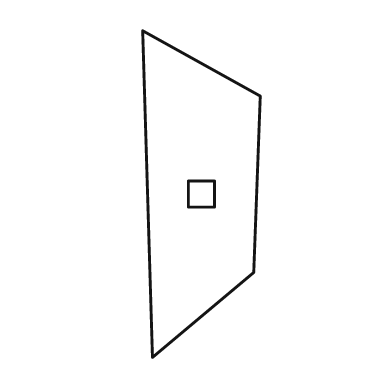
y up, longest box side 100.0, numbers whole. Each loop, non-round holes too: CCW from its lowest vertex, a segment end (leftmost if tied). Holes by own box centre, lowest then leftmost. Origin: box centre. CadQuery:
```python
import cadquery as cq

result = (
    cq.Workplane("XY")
    .moveTo(-15.0, -50.0)
    .lineTo(16.0, -24.0)
    .lineTo(18.0, 30.0)
    .lineTo(-18.0, 50.0)
    .close()
    .moveTo(-4.0, -4.0)
    .lineTo(4.0, -4.0)
    .lineTo(4.0, 4.0)
    .lineTo(-4.0, 4.0)
    .close()
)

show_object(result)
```